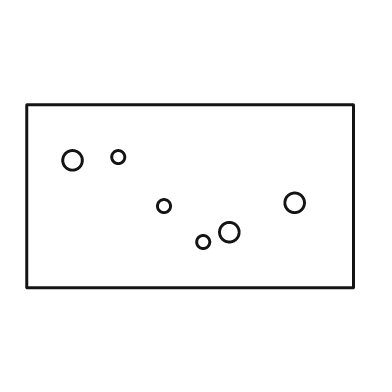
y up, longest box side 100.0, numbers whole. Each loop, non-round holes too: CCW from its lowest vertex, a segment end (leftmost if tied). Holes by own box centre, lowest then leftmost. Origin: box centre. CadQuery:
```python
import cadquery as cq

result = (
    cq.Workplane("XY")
    .moveTo(-50.0, -28.0)
    .lineTo(50.0, -28.0)
    .lineTo(50.0, 28.0)
    .lineTo(-50.0, 28.0)
    .close()
    .moveTo(4.0, -14.0)
    .circle(2.0)
    .moveTo(12.0, -11.0)
    .circle(3.0)
    .moveTo(-8.0, -3.0)
    .circle(2.0)
    .moveTo(32.0, -2.0)
    .circle(3.0)
    .moveTo(-36.0, 11.0)
    .circle(3.0)
    .moveTo(-22.0, 12.0)
    .circle(2.0)
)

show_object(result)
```